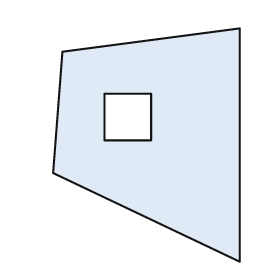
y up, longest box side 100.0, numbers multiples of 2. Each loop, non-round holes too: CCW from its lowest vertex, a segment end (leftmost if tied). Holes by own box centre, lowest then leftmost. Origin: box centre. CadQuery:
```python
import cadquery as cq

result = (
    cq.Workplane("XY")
    .moveTo(40.0, -50.0)
    .lineTo(40.0, 50.0)
    .lineTo(-36.0, 40.0)
    .lineTo(-40.0, -12.0)
    .close()
    .moveTo(-18.0, 2.0)
    .lineTo(2.0, 2.0)
    .lineTo(2.0, 22.0)
    .lineTo(-18.0, 22.0)
    .close()
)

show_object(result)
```